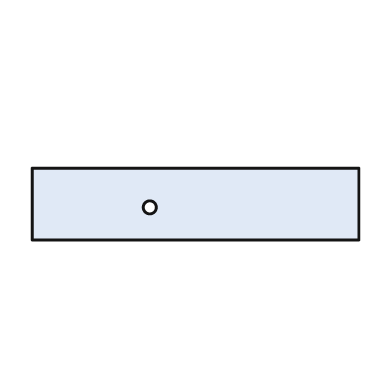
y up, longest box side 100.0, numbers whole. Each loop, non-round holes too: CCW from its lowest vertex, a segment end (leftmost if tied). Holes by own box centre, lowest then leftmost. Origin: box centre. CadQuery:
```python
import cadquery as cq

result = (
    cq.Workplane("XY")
    .moveTo(-50.0, -11.0)
    .lineTo(50.0, -11.0)
    .lineTo(50.0, 11.0)
    .lineTo(-50.0, 11.0)
    .close()
    .moveTo(-14.0, -1.0)
    .circle(2.0)
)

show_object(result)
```